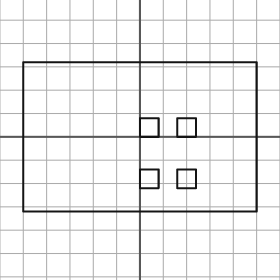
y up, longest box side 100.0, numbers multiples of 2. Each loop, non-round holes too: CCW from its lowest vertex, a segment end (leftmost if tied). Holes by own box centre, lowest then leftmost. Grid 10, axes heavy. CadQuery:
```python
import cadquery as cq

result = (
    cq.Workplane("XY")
    .moveTo(-50.0, -32.0)
    .lineTo(50.0, -32.0)
    .lineTo(50.0, 32.0)
    .lineTo(-50.0, 32.0)
    .close()
    .moveTo(0.0, -22.0)
    .lineTo(8.0, -22.0)
    .lineTo(8.0, -14.0)
    .lineTo(0.0, -14.0)
    .close()
    .moveTo(16.0, -22.0)
    .lineTo(24.0, -22.0)
    .lineTo(24.0, -14.0)
    .lineTo(16.0, -14.0)
    .close()
    .moveTo(0.0, 0.0)
    .lineTo(8.0, 0.0)
    .lineTo(8.0, 8.0)
    .lineTo(0.0, 8.0)
    .close()
    .moveTo(16.0, 0.0)
    .lineTo(24.0, 0.0)
    .lineTo(24.0, 8.0)
    .lineTo(16.0, 8.0)
    .close()
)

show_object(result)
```